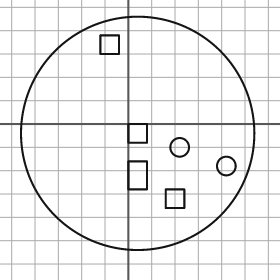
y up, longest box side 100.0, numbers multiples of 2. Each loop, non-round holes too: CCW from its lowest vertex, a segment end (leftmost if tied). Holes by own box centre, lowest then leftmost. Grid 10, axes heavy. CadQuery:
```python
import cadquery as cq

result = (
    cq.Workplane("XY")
    .moveTo(4.0, -4.0)
    .circle(50.0)
    .moveTo(16.0, -36.0)
    .lineTo(24.0, -36.0)
    .lineTo(24.0, -28.0)
    .lineTo(16.0, -28.0)
    .close()
    .moveTo(0.0, -28.0)
    .lineTo(8.0, -28.0)
    .lineTo(8.0, -16.0)
    .lineTo(0.0, -16.0)
    .close()
    .moveTo(42.0, -18.0)
    .circle(4.0)
    .moveTo(22.0, -10.0)
    .circle(4.0)
    .moveTo(0.0, -8.0)
    .lineTo(8.0, -8.0)
    .lineTo(8.0, 0.0)
    .lineTo(0.0, 0.0)
    .close()
    .moveTo(-12.0, 30.0)
    .lineTo(-4.0, 30.0)
    .lineTo(-4.0, 38.0)
    .lineTo(-12.0, 38.0)
    .close()
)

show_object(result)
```